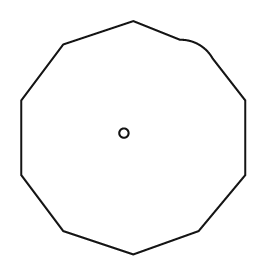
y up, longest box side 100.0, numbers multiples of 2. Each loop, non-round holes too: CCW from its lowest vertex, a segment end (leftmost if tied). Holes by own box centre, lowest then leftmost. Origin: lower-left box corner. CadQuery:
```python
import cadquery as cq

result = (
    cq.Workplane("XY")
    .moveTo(48.0, 0.0)
    .lineTo(76.0, 10.0)
    .lineTo(96.0, 34.0)
    .lineTo(96.0, 66.0)
    .lineTo(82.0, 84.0)
    .threePointArc((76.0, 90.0), (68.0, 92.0))
    .lineTo(48.0, 100.0)
    .lineTo(18.0, 90.0)
    .lineTo(0.0, 66.0)
    .lineTo(0.0, 34.0)
    .lineTo(18.0, 10.0)
    .close()
    .moveTo(44.0, 52.0)
    .circle(2.0)
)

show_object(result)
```